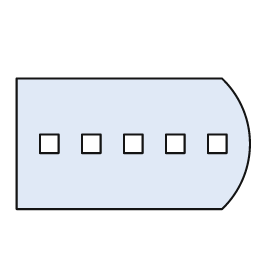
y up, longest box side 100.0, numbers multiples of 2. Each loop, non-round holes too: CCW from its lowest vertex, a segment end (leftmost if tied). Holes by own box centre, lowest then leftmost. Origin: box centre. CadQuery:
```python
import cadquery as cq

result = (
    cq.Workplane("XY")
    .moveTo(-50.0, -28.0)
    .lineTo(38.0, -28.0)
    .threePointArc((50.0, 0.0), (38.0, 28.0))
    .lineTo(-50.0, 28.0)
    .close()
    .moveTo(-40.0, -4.0)
    .lineTo(-32.0, -4.0)
    .lineTo(-32.0, 4.0)
    .lineTo(-40.0, 4.0)
    .close()
    .moveTo(-22.0, -4.0)
    .lineTo(-14.0, -4.0)
    .lineTo(-14.0, 4.0)
    .lineTo(-22.0, 4.0)
    .close()
    .moveTo(-4.0, -4.0)
    .lineTo(4.0, -4.0)
    .lineTo(4.0, 4.0)
    .lineTo(-4.0, 4.0)
    .close()
    .moveTo(14.0, -4.0)
    .lineTo(22.0, -4.0)
    .lineTo(22.0, 4.0)
    .lineTo(14.0, 4.0)
    .close()
    .moveTo(32.0, -4.0)
    .lineTo(40.0, -4.0)
    .lineTo(40.0, 4.0)
    .lineTo(32.0, 4.0)
    .close()
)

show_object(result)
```